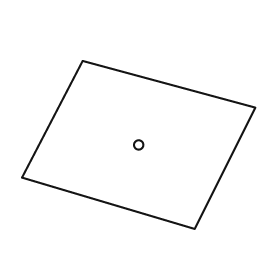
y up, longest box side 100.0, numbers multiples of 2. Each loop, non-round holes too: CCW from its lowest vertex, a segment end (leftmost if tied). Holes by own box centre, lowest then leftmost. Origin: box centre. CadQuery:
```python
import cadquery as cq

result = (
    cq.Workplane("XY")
    .moveTo(24.0, -36.0)
    .lineTo(50.0, 16.0)
    .lineTo(-24.0, 36.0)
    .lineTo(-50.0, -14.0)
    .close()
    .moveTo(0.0, 0.0)
    .circle(2.0)
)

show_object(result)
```